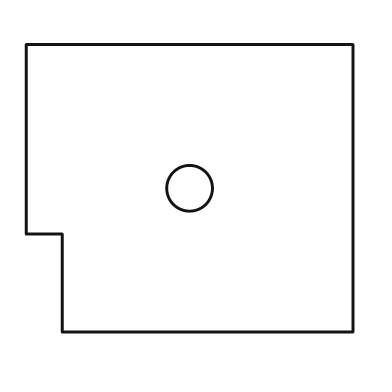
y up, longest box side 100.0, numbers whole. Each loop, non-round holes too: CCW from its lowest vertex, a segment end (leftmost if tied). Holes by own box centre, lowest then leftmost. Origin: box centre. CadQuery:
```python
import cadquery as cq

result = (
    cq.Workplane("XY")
    .moveTo(-39.0, -44.0)
    .lineTo(50.0, -44.0)
    .lineTo(50.0, 44.0)
    .lineTo(-50.0, 44.0)
    .lineTo(-50.0, -14.0)
    .lineTo(-39.0, -14.0)
    .close()
    .moveTo(0.0, 0.0)
    .circle(7.0)
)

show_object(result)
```